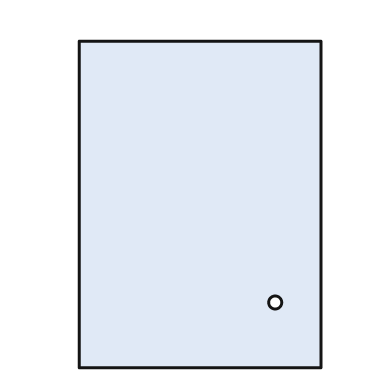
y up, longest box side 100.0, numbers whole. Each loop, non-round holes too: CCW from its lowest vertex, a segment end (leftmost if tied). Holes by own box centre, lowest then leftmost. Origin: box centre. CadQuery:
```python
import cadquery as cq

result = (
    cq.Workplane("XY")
    .moveTo(-37.0, -50.0)
    .lineTo(37.0, -50.0)
    .lineTo(37.0, 50.0)
    .lineTo(-37.0, 50.0)
    .close()
    .moveTo(23.0, -30.0)
    .circle(2.0)
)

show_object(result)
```